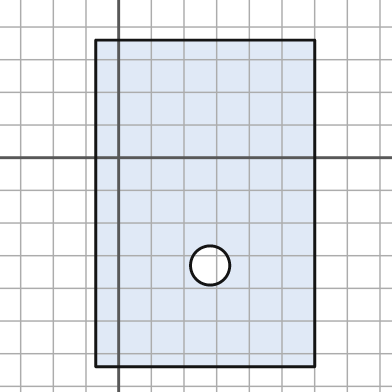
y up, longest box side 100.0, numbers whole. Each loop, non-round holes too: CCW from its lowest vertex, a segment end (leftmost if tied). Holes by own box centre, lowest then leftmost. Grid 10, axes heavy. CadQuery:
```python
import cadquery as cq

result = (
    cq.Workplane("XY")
    .moveTo(-7.0, -64.0)
    .lineTo(60.0, -64.0)
    .lineTo(60.0, 36.0)
    .lineTo(-7.0, 36.0)
    .close()
    .moveTo(28.0, -33.0)
    .circle(6.0)
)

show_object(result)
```